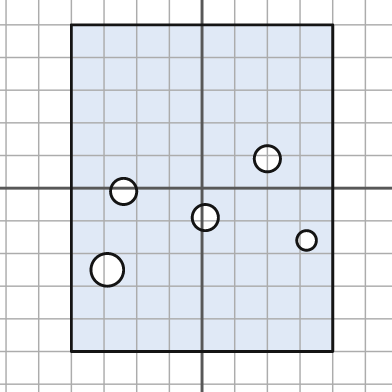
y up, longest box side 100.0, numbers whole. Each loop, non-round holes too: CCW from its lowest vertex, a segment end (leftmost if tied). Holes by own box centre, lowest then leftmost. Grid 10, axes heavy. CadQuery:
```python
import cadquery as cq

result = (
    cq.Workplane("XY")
    .moveTo(-40.0, -50.0)
    .lineTo(40.0, -50.0)
    .lineTo(40.0, 50.0)
    .lineTo(-40.0, 50.0)
    .close()
    .moveTo(-29.0, -25.0)
    .circle(5.0)
    .moveTo(32.0, -16.0)
    .circle(3.0)
    .moveTo(1.0, -9.0)
    .circle(4.0)
    .moveTo(-24.0, -1.0)
    .circle(4.0)
    .moveTo(20.0, 9.0)
    .circle(4.0)
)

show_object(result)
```